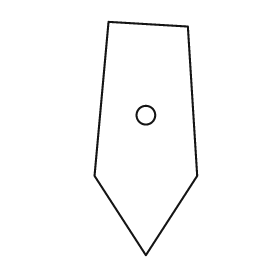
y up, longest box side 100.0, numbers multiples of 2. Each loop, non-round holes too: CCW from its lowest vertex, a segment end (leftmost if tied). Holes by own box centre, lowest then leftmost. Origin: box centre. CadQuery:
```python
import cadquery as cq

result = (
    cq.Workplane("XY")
    .moveTo(0.0, -50.0)
    .lineTo(22.0, -16.0)
    .lineTo(18.0, 48.0)
    .lineTo(-16.0, 50.0)
    .lineTo(-22.0, -16.0)
    .close()
    .moveTo(0.0, 10.0)
    .circle(4.0)
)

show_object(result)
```